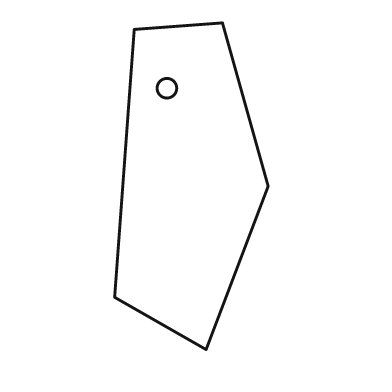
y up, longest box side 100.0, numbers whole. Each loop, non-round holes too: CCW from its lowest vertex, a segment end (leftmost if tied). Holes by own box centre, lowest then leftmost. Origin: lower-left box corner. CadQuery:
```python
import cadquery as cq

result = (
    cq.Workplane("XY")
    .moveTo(28.0, 0.0)
    .lineTo(47.0, 50.0)
    .lineTo(33.0, 100.0)
    .lineTo(6.0, 98.0)
    .lineTo(0.0, 16.0)
    .close()
    .moveTo(16.0, 80.0)
    .circle(3.0)
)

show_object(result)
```